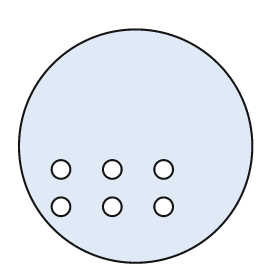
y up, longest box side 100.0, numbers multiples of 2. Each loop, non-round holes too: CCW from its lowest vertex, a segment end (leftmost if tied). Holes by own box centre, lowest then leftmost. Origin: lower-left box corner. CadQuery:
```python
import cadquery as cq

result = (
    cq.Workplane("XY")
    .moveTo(50.0, 50.0)
    .circle(50.0)
    .moveTo(18.0, 24.0)
    .circle(4.0)
    .moveTo(40.0, 24.0)
    .circle(4.0)
    .moveTo(62.0, 24.0)
    .circle(4.0)
    .moveTo(18.0, 40.0)
    .circle(4.0)
    .moveTo(40.0, 40.0)
    .circle(4.0)
    .moveTo(62.0, 40.0)
    .circle(4.0)
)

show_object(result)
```